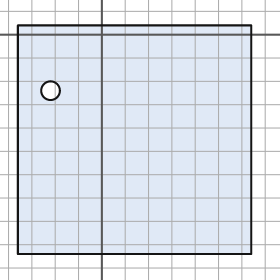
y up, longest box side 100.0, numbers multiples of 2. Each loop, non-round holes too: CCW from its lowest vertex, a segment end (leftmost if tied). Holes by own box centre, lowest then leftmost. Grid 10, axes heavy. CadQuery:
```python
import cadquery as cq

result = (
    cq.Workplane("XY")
    .moveTo(-36.0, -94.0)
    .lineTo(64.0, -94.0)
    .lineTo(64.0, 4.0)
    .lineTo(-36.0, 4.0)
    .close()
    .moveTo(-22.0, -24.0)
    .circle(4.0)
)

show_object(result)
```